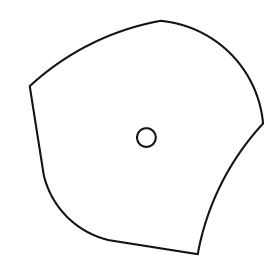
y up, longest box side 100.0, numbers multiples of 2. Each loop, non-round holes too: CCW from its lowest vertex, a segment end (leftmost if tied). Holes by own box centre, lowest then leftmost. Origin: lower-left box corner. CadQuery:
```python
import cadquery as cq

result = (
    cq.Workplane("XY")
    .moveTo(72.0, 0.0)
    .threePointArc((82.0, 30.0), (100.0, 56.0))
    .threePointArc((86.0, 86.0), (56.0, 100.0))
    .threePointArc((26.0, 90.0), (0.0, 72.0))
    .lineTo(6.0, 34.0)
    .threePointArc((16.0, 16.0), (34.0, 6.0))
    .close()
    .moveTo(50.0, 50.0)
    .circle(4.0)
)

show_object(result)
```